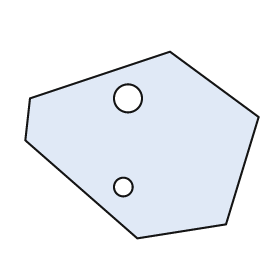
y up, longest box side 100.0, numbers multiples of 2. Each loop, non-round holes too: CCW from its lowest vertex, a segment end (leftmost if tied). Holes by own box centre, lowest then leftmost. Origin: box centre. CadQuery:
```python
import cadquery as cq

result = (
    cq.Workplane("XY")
    .moveTo(-2.0, -40.0)
    .lineTo(36.0, -34.0)
    .lineTo(50.0, 12.0)
    .lineTo(12.0, 40.0)
    .lineTo(-48.0, 20.0)
    .lineTo(-50.0, 2.0)
    .close()
    .moveTo(-8.0, -18.0)
    .circle(4.0)
    .moveTo(-6.0, 20.0)
    .circle(6.0)
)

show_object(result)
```